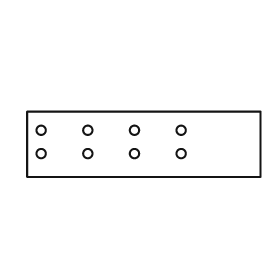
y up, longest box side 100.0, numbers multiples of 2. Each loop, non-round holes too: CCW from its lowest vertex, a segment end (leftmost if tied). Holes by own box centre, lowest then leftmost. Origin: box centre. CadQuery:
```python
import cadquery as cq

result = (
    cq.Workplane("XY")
    .moveTo(-50.0, -14.0)
    .lineTo(50.0, -14.0)
    .lineTo(50.0, 14.0)
    .lineTo(-50.0, 14.0)
    .close()
    .moveTo(-44.0, -4.0)
    .circle(2.0)
    .moveTo(-24.0, -4.0)
    .circle(2.0)
    .moveTo(-4.0, -4.0)
    .circle(2.0)
    .moveTo(16.0, -4.0)
    .circle(2.0)
    .moveTo(-44.0, 6.0)
    .circle(2.0)
    .moveTo(-24.0, 6.0)
    .circle(2.0)
    .moveTo(-4.0, 6.0)
    .circle(2.0)
    .moveTo(16.0, 6.0)
    .circle(2.0)
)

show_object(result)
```